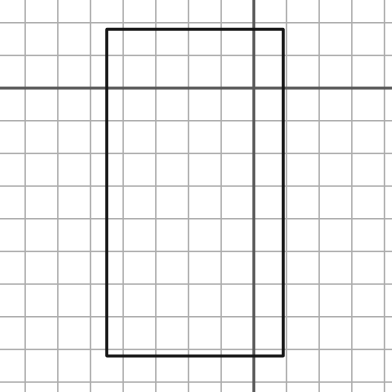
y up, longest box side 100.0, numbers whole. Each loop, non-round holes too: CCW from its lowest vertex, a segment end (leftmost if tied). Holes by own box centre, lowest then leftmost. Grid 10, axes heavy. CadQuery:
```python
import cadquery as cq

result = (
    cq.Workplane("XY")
    .moveTo(-45.0, -82.0)
    .lineTo(9.0, -82.0)
    .lineTo(9.0, 18.0)
    .lineTo(-45.0, 18.0)
    .close()
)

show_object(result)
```